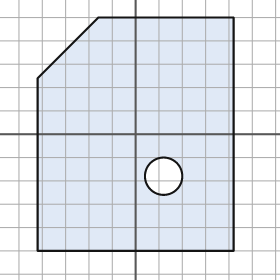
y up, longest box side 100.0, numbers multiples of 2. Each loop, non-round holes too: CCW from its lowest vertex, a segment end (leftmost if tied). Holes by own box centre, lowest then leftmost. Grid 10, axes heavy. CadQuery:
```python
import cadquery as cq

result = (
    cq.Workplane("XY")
    .moveTo(-42.0, -50.0)
    .lineTo(42.0, -50.0)
    .lineTo(42.0, 50.0)
    .lineTo(-16.0, 50.0)
    .lineTo(-42.0, 24.0)
    .close()
    .moveTo(12.0, -18.0)
    .circle(8.0)
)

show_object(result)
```